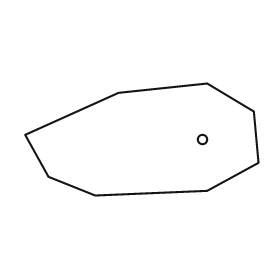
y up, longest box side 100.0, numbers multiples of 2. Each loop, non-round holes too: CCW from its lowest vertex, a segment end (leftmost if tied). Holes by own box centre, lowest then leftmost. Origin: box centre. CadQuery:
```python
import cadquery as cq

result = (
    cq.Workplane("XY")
    .moveTo(-20.0, -24.0)
    .lineTo(28.0, -22.0)
    .lineTo(50.0, -10.0)
    .lineTo(48.0, 12.0)
    .lineTo(28.0, 24.0)
    .lineTo(-10.0, 20.0)
    .lineTo(-50.0, 2.0)
    .lineTo(-40.0, -16.0)
    .close()
    .moveTo(26.0, 0.0)
    .circle(2.0)
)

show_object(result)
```